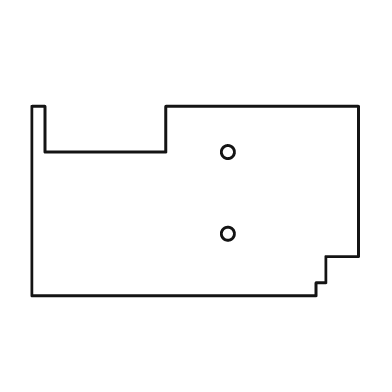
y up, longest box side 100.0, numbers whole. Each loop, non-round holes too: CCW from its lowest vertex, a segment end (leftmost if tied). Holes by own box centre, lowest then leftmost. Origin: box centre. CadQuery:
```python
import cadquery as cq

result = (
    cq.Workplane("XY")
    .moveTo(-50.0, -29.0)
    .lineTo(37.0, -29.0)
    .lineTo(37.0, -25.0)
    .lineTo(40.0, -25.0)
    .lineTo(40.0, -17.0)
    .lineTo(50.0, -17.0)
    .lineTo(50.0, 29.0)
    .lineTo(-9.0, 29.0)
    .lineTo(-9.0, 15.0)
    .lineTo(-46.0, 15.0)
    .lineTo(-46.0, 29.0)
    .lineTo(-50.0, 29.0)
    .close()
    .moveTo(10.0, -10.0)
    .circle(2.0)
    .moveTo(10.0, 15.0)
    .circle(2.0)
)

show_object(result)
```